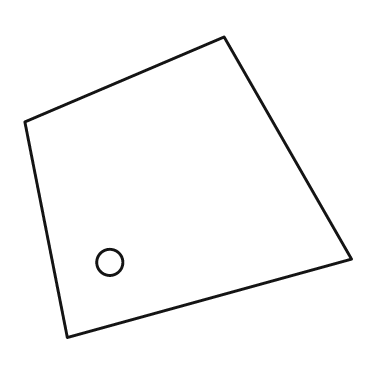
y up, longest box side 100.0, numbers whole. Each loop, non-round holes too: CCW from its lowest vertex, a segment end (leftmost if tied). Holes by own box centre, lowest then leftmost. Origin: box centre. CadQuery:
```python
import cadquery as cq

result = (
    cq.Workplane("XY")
    .moveTo(-37.0, -46.0)
    .lineTo(50.0, -22.0)
    .lineTo(11.0, 46.0)
    .lineTo(-50.0, 20.0)
    .close()
    .moveTo(-24.0, -23.0)
    .circle(4.0)
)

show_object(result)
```